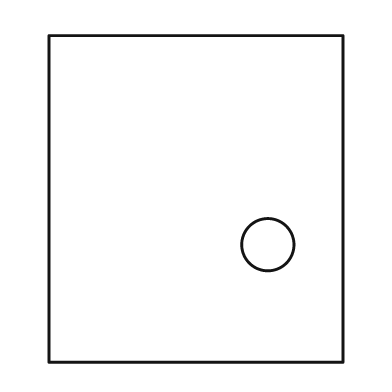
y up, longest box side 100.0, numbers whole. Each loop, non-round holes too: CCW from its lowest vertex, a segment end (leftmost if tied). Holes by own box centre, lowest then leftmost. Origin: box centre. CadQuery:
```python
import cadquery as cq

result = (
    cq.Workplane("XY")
    .moveTo(-45.0, -50.0)
    .lineTo(45.0, -50.0)
    .lineTo(45.0, 50.0)
    .lineTo(-45.0, 50.0)
    .close()
    .moveTo(22.0, -14.0)
    .circle(8.0)
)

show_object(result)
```